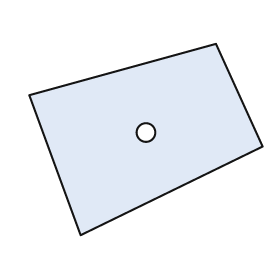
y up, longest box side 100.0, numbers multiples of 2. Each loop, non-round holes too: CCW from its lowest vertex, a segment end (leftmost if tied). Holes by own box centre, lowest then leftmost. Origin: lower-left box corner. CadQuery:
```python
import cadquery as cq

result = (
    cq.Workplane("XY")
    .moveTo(22.0, 0.0)
    .lineTo(100.0, 38.0)
    .lineTo(80.0, 82.0)
    .lineTo(0.0, 60.0)
    .close()
    .moveTo(50.0, 44.0)
    .circle(4.0)
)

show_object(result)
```